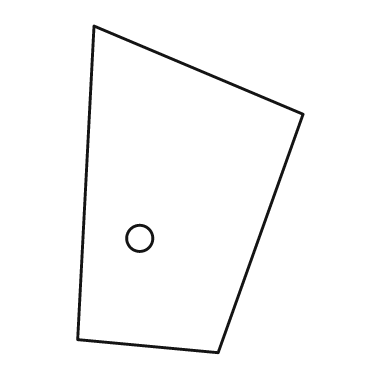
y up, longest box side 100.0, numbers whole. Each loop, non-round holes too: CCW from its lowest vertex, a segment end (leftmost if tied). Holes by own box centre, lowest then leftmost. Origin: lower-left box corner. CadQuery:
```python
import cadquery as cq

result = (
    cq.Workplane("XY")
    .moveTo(43.0, 0.0)
    .lineTo(69.0, 73.0)
    .lineTo(5.0, 100.0)
    .lineTo(0.0, 4.0)
    .close()
    .moveTo(19.0, 35.0)
    .circle(4.0)
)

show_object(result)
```